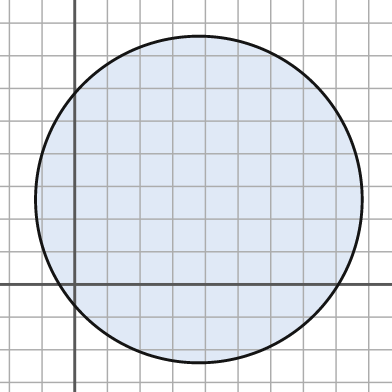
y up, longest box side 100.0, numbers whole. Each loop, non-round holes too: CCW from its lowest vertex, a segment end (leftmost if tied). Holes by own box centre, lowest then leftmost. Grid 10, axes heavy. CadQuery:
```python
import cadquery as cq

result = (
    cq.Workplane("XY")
    .moveTo(38.0, 26.0)
    .circle(50.0)
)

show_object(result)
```